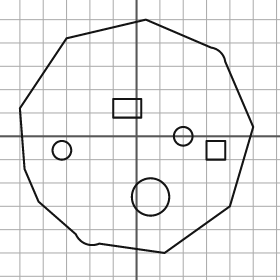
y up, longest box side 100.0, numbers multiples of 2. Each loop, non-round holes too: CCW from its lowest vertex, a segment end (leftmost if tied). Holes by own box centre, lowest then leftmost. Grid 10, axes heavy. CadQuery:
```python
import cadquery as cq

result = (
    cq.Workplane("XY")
    .moveTo(12.0, -50.0)
    .lineTo(40.0, -30.0)
    .lineTo(50.0, 4.0)
    .lineTo(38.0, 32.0)
    .threePointArc((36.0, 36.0), (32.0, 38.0))
    .lineTo(4.0, 50.0)
    .lineTo(-30.0, 42.0)
    .lineTo(-50.0, 12.0)
    .lineTo(-48.0, -14.0)
    .lineTo(-42.0, -28.0)
    .lineTo(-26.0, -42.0)
    .threePointArc((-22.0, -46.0), (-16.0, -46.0))
    .close()
    .moveTo(6.0, -26.0)
    .circle(8.0)
    .moveTo(-32.0, -6.0)
    .circle(4.0)
    .moveTo(30.0, -10.0)
    .lineTo(38.0, -10.0)
    .lineTo(38.0, -2.0)
    .lineTo(30.0, -2.0)
    .close()
    .moveTo(20.0, 0.0)
    .circle(4.0)
    .moveTo(-10.0, 8.0)
    .lineTo(2.0, 8.0)
    .lineTo(2.0, 16.0)
    .lineTo(-10.0, 16.0)
    .close()
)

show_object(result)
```